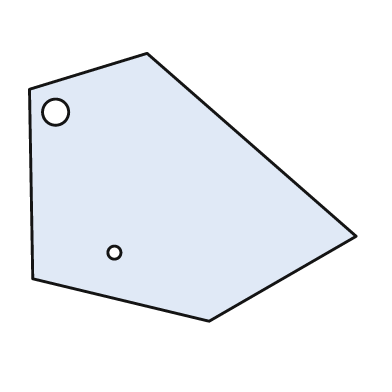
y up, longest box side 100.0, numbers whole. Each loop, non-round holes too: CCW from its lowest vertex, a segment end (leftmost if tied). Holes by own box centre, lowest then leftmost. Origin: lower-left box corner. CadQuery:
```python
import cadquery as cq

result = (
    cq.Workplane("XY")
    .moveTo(55.0, 0.0)
    .lineTo(100.0, 26.0)
    .lineTo(36.0, 82.0)
    .lineTo(0.0, 71.0)
    .lineTo(1.0, 13.0)
    .close()
    .moveTo(26.0, 21.0)
    .circle(2.0)
    .moveTo(8.0, 64.0)
    .circle(4.0)
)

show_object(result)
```